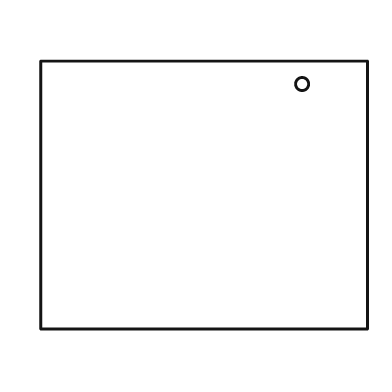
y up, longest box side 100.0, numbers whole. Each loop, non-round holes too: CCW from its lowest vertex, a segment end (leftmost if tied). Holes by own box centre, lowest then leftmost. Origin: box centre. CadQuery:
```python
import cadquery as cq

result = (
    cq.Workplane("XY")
    .moveTo(-50.0, -41.0)
    .lineTo(50.0, -41.0)
    .lineTo(50.0, 41.0)
    .lineTo(-50.0, 41.0)
    .close()
    .moveTo(30.0, 34.0)
    .circle(2.0)
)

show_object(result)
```